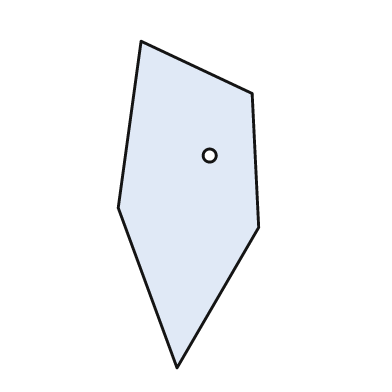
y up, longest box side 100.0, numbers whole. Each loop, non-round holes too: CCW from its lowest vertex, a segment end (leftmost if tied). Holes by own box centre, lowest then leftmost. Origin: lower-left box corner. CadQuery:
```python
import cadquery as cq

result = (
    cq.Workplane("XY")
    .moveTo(18.0, 0.0)
    .lineTo(43.0, 43.0)
    .lineTo(41.0, 84.0)
    .lineTo(7.0, 100.0)
    .lineTo(0.0, 49.0)
    .close()
    .moveTo(28.0, 65.0)
    .circle(2.0)
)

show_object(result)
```